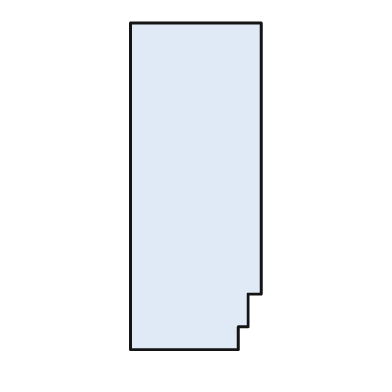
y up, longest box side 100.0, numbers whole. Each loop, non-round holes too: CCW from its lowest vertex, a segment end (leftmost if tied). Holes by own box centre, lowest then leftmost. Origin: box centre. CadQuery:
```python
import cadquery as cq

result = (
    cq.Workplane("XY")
    .moveTo(-20.0, -50.0)
    .lineTo(13.0, -50.0)
    .lineTo(13.0, -43.0)
    .lineTo(16.0, -43.0)
    .lineTo(16.0, -33.0)
    .lineTo(20.0, -33.0)
    .lineTo(20.0, 50.0)
    .lineTo(-20.0, 50.0)
    .close()
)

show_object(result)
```